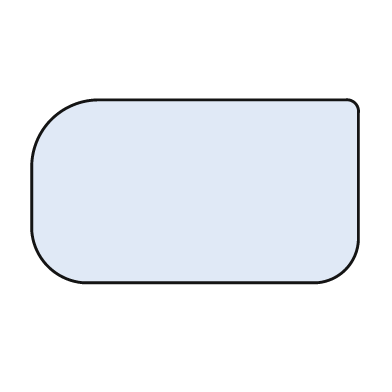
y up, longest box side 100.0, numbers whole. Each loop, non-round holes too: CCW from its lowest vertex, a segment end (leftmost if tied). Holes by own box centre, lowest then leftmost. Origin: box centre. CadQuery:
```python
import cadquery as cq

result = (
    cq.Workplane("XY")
    .moveTo(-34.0, -28.0)
    .lineTo(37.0, -28.0)
    .threePointArc((46.0, -24.0), (50.0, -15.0))
    .lineTo(50.0, 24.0)
    .threePointArc((49.0, 27.0), (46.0, 28.0))
    .lineTo(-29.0, 28.0)
    .threePointArc((-44.0, 22.0), (-50.0, 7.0))
    .lineTo(-50.0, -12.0)
    .threePointArc((-45.0, -23.0), (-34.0, -28.0))
    .close()
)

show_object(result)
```